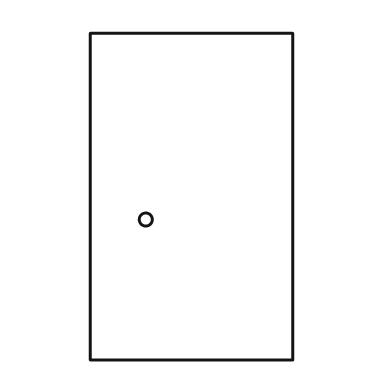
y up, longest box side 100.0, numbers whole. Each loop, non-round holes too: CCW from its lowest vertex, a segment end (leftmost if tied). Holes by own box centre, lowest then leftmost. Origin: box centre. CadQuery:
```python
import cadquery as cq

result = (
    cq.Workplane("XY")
    .moveTo(-31.0, -50.0)
    .lineTo(31.0, -50.0)
    .lineTo(31.0, 50.0)
    .lineTo(-31.0, 50.0)
    .close()
    .moveTo(-14.0, -7.0)
    .circle(2.0)
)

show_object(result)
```